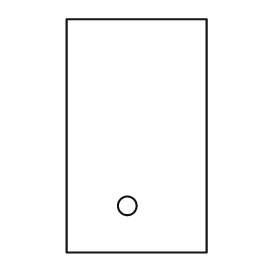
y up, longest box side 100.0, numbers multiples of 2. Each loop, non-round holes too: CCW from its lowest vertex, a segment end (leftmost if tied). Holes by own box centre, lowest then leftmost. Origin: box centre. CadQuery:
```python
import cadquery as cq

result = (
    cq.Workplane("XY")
    .moveTo(-30.0, -50.0)
    .lineTo(30.0, -50.0)
    .lineTo(30.0, 50.0)
    .lineTo(-30.0, 50.0)
    .close()
    .moveTo(-4.0, -30.0)
    .circle(4.0)
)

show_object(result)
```